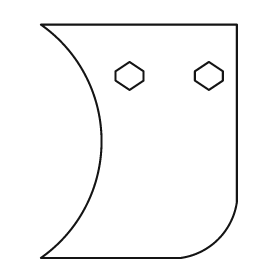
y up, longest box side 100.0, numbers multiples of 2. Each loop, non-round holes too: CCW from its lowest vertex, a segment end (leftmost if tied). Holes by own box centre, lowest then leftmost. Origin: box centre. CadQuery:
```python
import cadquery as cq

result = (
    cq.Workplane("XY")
    .moveTo(-42.0, -50.0)
    .lineTo(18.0, -50.0)
    .threePointArc((34.0, -42.0), (42.0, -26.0))
    .lineTo(42.0, 50.0)
    .lineTo(-42.0, 50.0)
    .threePointArc((-16.0, 0.0), (-42.0, -50.0))
    .close()
    .moveTo(-4.0, 22.0)
    .lineTo(2.0, 26.0)
    .lineTo(2.0, 30.0)
    .lineTo(-4.0, 34.0)
    .lineTo(-10.0, 30.0)
    .lineTo(-10.0, 26.0)
    .close()
    .moveTo(30.0, 22.0)
    .lineTo(36.0, 26.0)
    .lineTo(36.0, 30.0)
    .lineTo(30.0, 34.0)
    .lineTo(24.0, 30.0)
    .lineTo(24.0, 26.0)
    .close()
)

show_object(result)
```